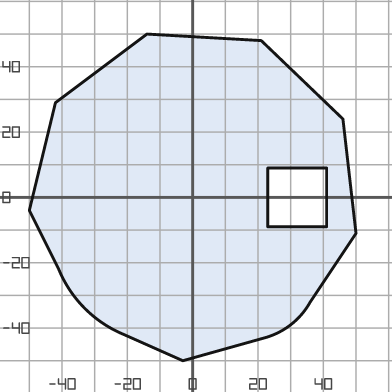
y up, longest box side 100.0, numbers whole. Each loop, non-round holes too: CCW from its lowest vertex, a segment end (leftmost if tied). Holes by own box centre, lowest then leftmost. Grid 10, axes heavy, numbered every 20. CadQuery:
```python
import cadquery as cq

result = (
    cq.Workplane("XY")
    .moveTo(-3.0, -50.0)
    .lineTo(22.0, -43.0)
    .threePointArc((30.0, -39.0), (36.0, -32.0))
    .lineTo(50.0, -11.0)
    .lineTo(46.0, 24.0)
    .lineTo(21.0, 48.0)
    .lineTo(-14.0, 50.0)
    .lineTo(-42.0, 29.0)
    .lineTo(-50.0, -4.0)
    .lineTo(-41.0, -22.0)
    .threePointArc((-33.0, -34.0), (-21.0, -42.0))
    .close()
    .moveTo(23.0, -9.0)
    .lineTo(41.0, -9.0)
    .lineTo(41.0, 9.0)
    .lineTo(23.0, 9.0)
    .close()
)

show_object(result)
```